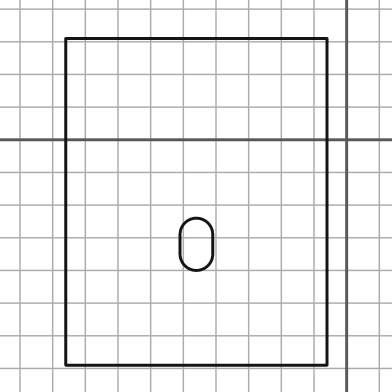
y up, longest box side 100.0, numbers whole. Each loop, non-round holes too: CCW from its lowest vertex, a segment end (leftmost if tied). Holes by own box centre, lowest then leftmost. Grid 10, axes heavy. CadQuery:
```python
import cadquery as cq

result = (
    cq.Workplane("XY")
    .moveTo(-86.0, -69.0)
    .lineTo(-6.0, -69.0)
    .lineTo(-6.0, 31.0)
    .lineTo(-86.0, 31.0)
    .close()
    .moveTo(-51.0, -35.0)
    .threePointArc((-46.0, -40.0), (-41.0, -35.0))
    .lineTo(-41.0, -29.0)
    .threePointArc((-46.0, -24.0), (-51.0, -29.0))
    .close()
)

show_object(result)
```